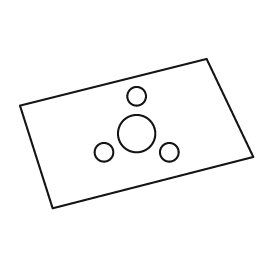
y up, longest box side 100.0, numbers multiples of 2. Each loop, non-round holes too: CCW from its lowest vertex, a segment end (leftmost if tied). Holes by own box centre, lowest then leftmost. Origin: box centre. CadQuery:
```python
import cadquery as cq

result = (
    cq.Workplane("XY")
    .moveTo(-36.0, -32.0)
    .lineTo(50.0, -10.0)
    .lineTo(30.0, 32.0)
    .lineTo(-50.0, 12.0)
    .close()
    .moveTo(-14.0, -8.0)
    .circle(4.0)
    .moveTo(14.0, -8.0)
    .circle(4.0)
    .moveTo(0.0, 0.0)
    .circle(8.0)
    .moveTo(0.0, 16.0)
    .circle(4.0)
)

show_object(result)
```